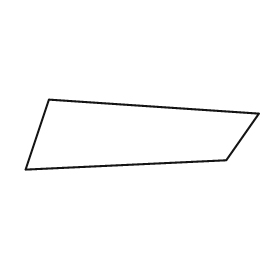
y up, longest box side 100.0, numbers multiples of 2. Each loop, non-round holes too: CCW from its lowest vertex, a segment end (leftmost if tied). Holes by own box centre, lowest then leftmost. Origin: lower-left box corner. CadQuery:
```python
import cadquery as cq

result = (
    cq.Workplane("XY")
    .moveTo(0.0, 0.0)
    .lineTo(86.0, 4.0)
    .lineTo(100.0, 24.0)
    .lineTo(10.0, 30.0)
    .close()
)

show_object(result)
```